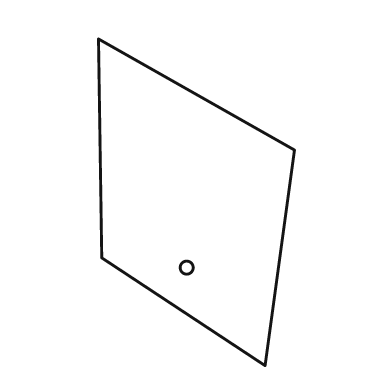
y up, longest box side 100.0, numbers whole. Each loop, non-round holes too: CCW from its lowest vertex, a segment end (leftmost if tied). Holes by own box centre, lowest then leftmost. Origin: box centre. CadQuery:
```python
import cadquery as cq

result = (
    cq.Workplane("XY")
    .moveTo(21.0, -50.0)
    .lineTo(30.0, 16.0)
    .lineTo(-30.0, 50.0)
    .lineTo(-29.0, -17.0)
    .close()
    .moveTo(-3.0, -20.0)
    .circle(2.0)
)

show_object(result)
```